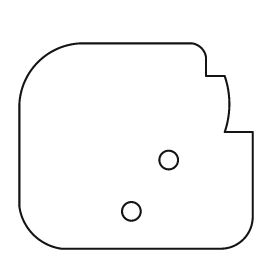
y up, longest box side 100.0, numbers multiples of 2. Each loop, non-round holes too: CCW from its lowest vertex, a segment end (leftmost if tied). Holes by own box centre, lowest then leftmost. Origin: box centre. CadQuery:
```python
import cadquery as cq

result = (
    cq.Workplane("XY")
    .moveTo(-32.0, -44.0)
    .lineTo(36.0, -44.0)
    .threePointArc((46.0, -40.0), (50.0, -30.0))
    .lineTo(50.0, 6.0)
    .lineTo(38.0, 6.0)
    .threePointArc((40.0, 18.0), (38.0, 30.0))
    .lineTo(30.0, 30.0)
    .lineTo(30.0, 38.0)
    .threePointArc((28.0, 42.0), (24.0, 44.0))
    .lineTo(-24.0, 44.0)
    .threePointArc((-42.0, 36.0), (-50.0, 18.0))
    .lineTo(-50.0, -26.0)
    .threePointArc((-44.0, -38.0), (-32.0, -44.0))
    .close()
    .moveTo(-2.0, -28.0)
    .circle(4.0)
    .moveTo(14.0, -6.0)
    .circle(4.0)
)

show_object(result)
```